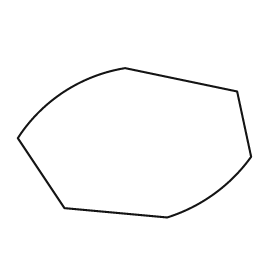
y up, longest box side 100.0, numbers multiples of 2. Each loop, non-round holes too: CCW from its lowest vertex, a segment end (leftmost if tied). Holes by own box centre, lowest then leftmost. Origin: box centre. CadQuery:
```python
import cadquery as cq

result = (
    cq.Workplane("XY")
    .moveTo(14.0, -32.0)
    .threePointArc((34.0, -22.0), (50.0, -6.0))
    .lineTo(44.0, 22.0)
    .lineTo(-4.0, 32.0)
    .threePointArc((-30.0, 22.0), (-50.0, 2.0))
    .lineTo(-30.0, -28.0)
    .close()
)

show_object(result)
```